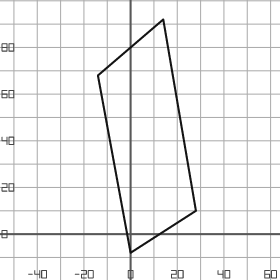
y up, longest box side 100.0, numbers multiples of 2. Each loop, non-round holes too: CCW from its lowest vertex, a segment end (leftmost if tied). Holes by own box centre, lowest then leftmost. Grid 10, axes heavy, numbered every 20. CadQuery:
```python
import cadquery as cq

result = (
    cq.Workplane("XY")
    .moveTo(0.0, -8.0)
    .lineTo(28.0, 10.0)
    .lineTo(14.0, 92.0)
    .lineTo(-14.0, 68.0)
    .close()
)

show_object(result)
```